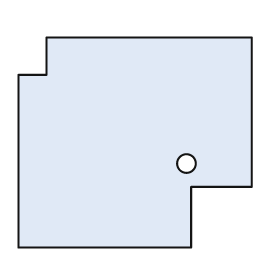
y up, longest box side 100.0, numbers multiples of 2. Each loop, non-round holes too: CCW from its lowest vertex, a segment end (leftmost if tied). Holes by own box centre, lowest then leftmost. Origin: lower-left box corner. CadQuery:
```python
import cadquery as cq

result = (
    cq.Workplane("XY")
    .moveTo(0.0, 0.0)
    .lineTo(74.0, 0.0)
    .lineTo(74.0, 26.0)
    .lineTo(100.0, 26.0)
    .lineTo(100.0, 90.0)
    .lineTo(12.0, 90.0)
    .lineTo(12.0, 74.0)
    .lineTo(0.0, 74.0)
    .close()
    .moveTo(72.0, 36.0)
    .circle(4.0)
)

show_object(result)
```